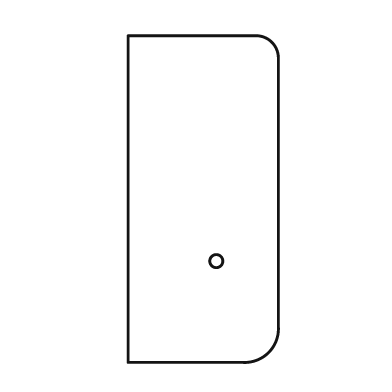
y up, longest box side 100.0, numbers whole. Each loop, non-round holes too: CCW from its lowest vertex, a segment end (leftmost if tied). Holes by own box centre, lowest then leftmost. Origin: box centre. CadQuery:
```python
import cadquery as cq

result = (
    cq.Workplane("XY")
    .moveTo(-23.0, -50.0)
    .lineTo(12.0, -50.0)
    .threePointArc((20.0, -47.0), (23.0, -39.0))
    .lineTo(23.0, 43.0)
    .threePointArc((21.0, 48.0), (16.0, 50.0))
    .lineTo(-23.0, 50.0)
    .close()
    .moveTo(4.0, -19.0)
    .circle(2.0)
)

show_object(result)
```